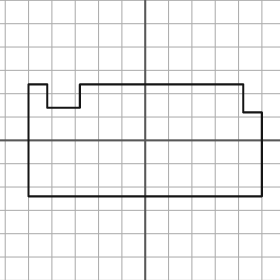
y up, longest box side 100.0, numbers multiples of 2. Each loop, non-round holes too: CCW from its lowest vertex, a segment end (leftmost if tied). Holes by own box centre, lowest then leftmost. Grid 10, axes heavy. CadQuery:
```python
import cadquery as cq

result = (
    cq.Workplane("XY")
    .moveTo(-50.0, -24.0)
    .lineTo(50.0, -24.0)
    .lineTo(50.0, 12.0)
    .lineTo(42.0, 12.0)
    .lineTo(42.0, 24.0)
    .lineTo(-28.0, 24.0)
    .lineTo(-28.0, 14.0)
    .lineTo(-42.0, 14.0)
    .lineTo(-42.0, 24.0)
    .lineTo(-50.0, 24.0)
    .close()
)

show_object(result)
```